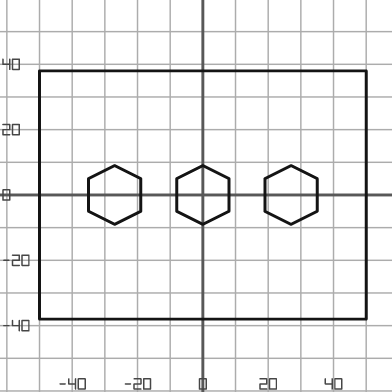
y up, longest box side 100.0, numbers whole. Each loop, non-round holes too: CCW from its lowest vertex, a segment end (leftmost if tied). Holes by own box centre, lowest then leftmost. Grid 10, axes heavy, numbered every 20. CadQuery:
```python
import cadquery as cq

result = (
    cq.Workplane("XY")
    .moveTo(-50.0, -38.0)
    .lineTo(50.0, -38.0)
    .lineTo(50.0, 38.0)
    .lineTo(-50.0, 38.0)
    .close()
    .moveTo(-27.0, -9.0)
    .lineTo(-19.0, -5.0)
    .lineTo(-19.0, 5.0)
    .lineTo(-27.0, 9.0)
    .lineTo(-35.0, 5.0)
    .lineTo(-35.0, -5.0)
    .close()
    .moveTo(0.0, -9.0)
    .lineTo(8.0, -5.0)
    .lineTo(8.0, 5.0)
    .lineTo(0.0, 9.0)
    .lineTo(-8.0, 5.0)
    .lineTo(-8.0, -5.0)
    .close()
    .moveTo(27.0, -9.0)
    .lineTo(35.0, -5.0)
    .lineTo(35.0, 5.0)
    .lineTo(27.0, 9.0)
    .lineTo(19.0, 5.0)
    .lineTo(19.0, -5.0)
    .close()
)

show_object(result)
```